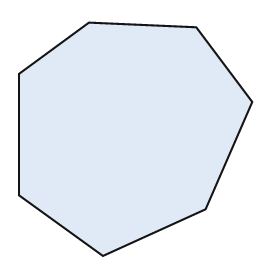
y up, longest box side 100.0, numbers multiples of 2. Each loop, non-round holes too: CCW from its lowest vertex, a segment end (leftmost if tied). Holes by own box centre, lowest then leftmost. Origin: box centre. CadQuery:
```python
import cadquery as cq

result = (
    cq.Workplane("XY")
    .moveTo(-14.0, -50.0)
    .lineTo(30.0, -30.0)
    .lineTo(50.0, 16.0)
    .lineTo(26.0, 48.0)
    .lineTo(-20.0, 50.0)
    .lineTo(-50.0, 28.0)
    .lineTo(-50.0, -24.0)
    .close()
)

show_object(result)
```